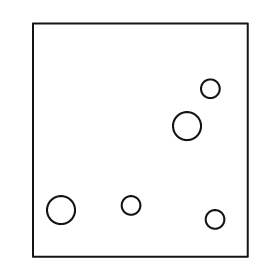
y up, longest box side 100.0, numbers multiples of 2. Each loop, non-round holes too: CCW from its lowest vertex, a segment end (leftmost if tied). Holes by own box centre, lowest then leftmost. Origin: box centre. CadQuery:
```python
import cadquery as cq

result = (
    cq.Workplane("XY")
    .moveTo(-46.0, -50.0)
    .lineTo(46.0, -50.0)
    .lineTo(46.0, 50.0)
    .lineTo(-46.0, 50.0)
    .close()
    .moveTo(32.0, -34.0)
    .circle(4.0)
    .moveTo(-34.0, -30.0)
    .circle(6.0)
    .moveTo(-4.0, -28.0)
    .circle(4.0)
    .moveTo(20.0, 6.0)
    .circle(6.0)
    .moveTo(30.0, 22.0)
    .circle(4.0)
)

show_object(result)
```